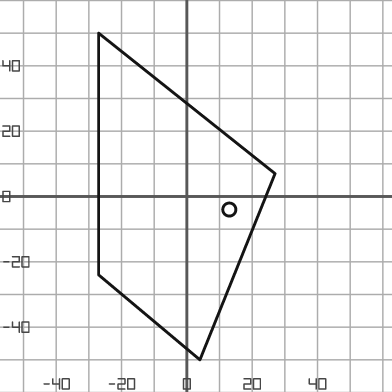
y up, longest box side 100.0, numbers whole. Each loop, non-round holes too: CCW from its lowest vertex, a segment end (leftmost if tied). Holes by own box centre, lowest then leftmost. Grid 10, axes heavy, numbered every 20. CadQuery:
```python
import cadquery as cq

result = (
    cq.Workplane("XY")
    .moveTo(4.0, -50.0)
    .lineTo(27.0, 7.0)
    .lineTo(-27.0, 50.0)
    .lineTo(-27.0, -24.0)
    .close()
    .moveTo(13.0, -4.0)
    .circle(2.0)
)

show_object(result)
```